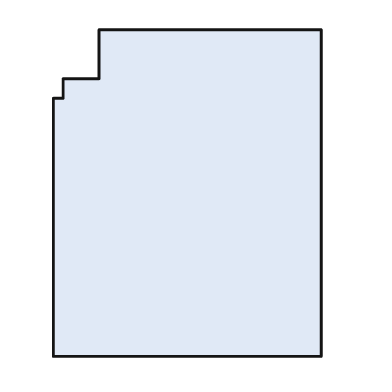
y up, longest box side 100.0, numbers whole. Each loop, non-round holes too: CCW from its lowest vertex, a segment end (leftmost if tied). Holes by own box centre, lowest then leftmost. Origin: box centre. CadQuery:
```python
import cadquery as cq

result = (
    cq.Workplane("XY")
    .moveTo(-41.0, -50.0)
    .lineTo(41.0, -50.0)
    .lineTo(41.0, 50.0)
    .lineTo(-27.0, 50.0)
    .lineTo(-27.0, 35.0)
    .lineTo(-38.0, 35.0)
    .lineTo(-38.0, 29.0)
    .lineTo(-41.0, 29.0)
    .close()
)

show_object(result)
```